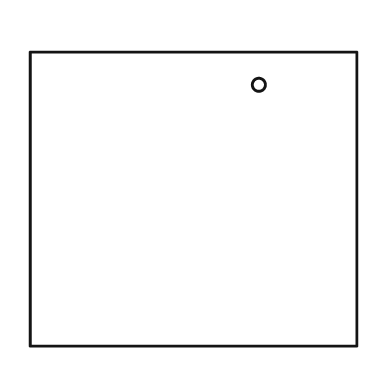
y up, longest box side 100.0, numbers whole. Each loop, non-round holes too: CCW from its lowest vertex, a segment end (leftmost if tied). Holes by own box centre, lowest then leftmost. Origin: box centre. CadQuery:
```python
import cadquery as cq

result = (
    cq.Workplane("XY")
    .moveTo(-50.0, -45.0)
    .lineTo(50.0, -45.0)
    .lineTo(50.0, 45.0)
    .lineTo(-50.0, 45.0)
    .close()
    .moveTo(20.0, 35.0)
    .circle(2.0)
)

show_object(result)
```